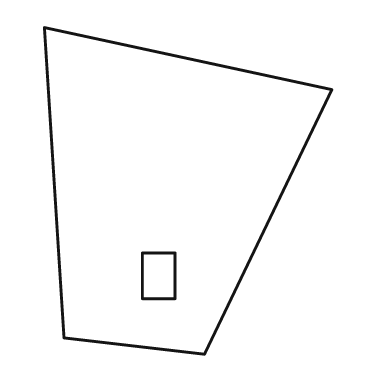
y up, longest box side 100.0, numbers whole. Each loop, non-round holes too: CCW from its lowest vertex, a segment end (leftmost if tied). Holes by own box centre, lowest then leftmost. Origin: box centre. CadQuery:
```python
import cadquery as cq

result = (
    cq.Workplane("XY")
    .moveTo(5.0, -50.0)
    .lineTo(44.0, 31.0)
    .lineTo(-44.0, 50.0)
    .lineTo(-38.0, -45.0)
    .close()
    .moveTo(-14.0, -33.0)
    .lineTo(-4.0, -33.0)
    .lineTo(-4.0, -19.0)
    .lineTo(-14.0, -19.0)
    .close()
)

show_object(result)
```